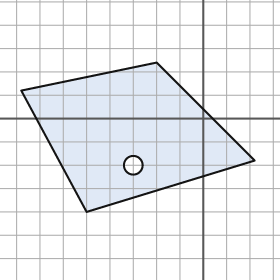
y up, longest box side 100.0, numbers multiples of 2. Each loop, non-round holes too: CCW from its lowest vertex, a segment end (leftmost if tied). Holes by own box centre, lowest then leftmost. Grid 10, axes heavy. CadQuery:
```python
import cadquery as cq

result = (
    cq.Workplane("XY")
    .moveTo(-50.0, -40.0)
    .lineTo(22.0, -18.0)
    .lineTo(-20.0, 24.0)
    .lineTo(-78.0, 12.0)
    .close()
    .moveTo(-30.0, -20.0)
    .circle(4.0)
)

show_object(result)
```